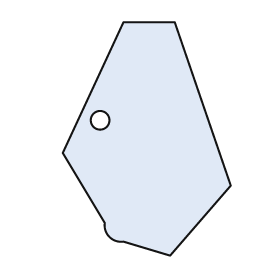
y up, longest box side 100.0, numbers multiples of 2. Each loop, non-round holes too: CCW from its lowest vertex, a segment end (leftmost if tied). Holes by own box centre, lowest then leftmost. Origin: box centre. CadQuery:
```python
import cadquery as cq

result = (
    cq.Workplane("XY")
    .moveTo(10.0, -50.0)
    .lineTo(36.0, -20.0)
    .lineTo(12.0, 50.0)
    .lineTo(-10.0, 50.0)
    .lineTo(-36.0, -6.0)
    .lineTo(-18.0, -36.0)
    .threePointArc((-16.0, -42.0), (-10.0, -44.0))
    .close()
    .moveTo(-20.0, 8.0)
    .circle(4.0)
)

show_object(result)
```